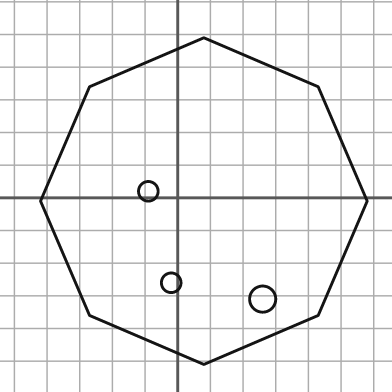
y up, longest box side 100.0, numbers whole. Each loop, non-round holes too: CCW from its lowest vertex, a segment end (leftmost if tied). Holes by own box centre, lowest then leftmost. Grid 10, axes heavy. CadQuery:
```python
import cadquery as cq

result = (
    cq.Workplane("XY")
    .moveTo(8.0, -51.0)
    .lineTo(43.0, -36.0)
    .lineTo(58.0, -1.0)
    .lineTo(43.0, 34.0)
    .lineTo(8.0, 49.0)
    .lineTo(-27.0, 34.0)
    .lineTo(-42.0, -1.0)
    .lineTo(-27.0, -36.0)
    .close()
    .moveTo(26.0, -31.0)
    .circle(4.0)
    .moveTo(-2.0, -26.0)
    .circle(3.0)
    .moveTo(-9.0, 2.0)
    .circle(3.0)
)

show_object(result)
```